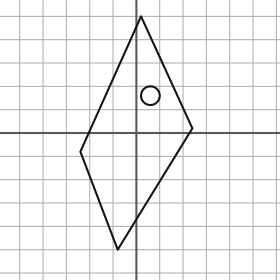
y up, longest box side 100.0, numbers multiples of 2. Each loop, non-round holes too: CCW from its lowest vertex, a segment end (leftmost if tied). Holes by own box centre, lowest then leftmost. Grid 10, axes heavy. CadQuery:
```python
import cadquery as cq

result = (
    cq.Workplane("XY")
    .moveTo(-8.0, -50.0)
    .lineTo(24.0, 2.0)
    .lineTo(2.0, 50.0)
    .lineTo(-24.0, -8.0)
    .close()
    .moveTo(6.0, 16.0)
    .circle(4.0)
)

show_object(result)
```